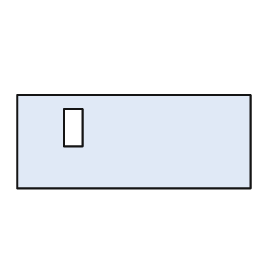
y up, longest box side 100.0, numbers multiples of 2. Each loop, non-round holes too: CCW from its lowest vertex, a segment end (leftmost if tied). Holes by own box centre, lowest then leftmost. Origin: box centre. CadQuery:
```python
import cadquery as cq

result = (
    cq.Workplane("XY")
    .moveTo(-50.0, -20.0)
    .lineTo(50.0, -20.0)
    .lineTo(50.0, 20.0)
    .lineTo(-50.0, 20.0)
    .close()
    .moveTo(-30.0, -2.0)
    .lineTo(-22.0, -2.0)
    .lineTo(-22.0, 14.0)
    .lineTo(-30.0, 14.0)
    .close()
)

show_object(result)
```